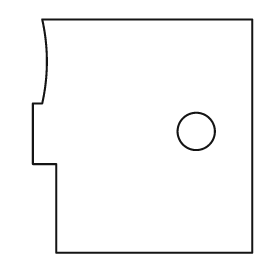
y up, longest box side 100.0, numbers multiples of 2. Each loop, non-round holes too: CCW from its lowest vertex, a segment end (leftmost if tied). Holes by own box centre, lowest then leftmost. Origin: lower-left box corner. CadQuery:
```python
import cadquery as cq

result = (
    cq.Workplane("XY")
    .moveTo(10.0, 0.0)
    .lineTo(94.0, 0.0)
    .lineTo(94.0, 100.0)
    .lineTo(4.0, 100.0)
    .threePointArc((6.0, 82.0), (4.0, 64.0))
    .lineTo(0.0, 64.0)
    .lineTo(0.0, 38.0)
    .lineTo(10.0, 38.0)
    .close()
    .moveTo(70.0, 52.0)
    .circle(8.0)
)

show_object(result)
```